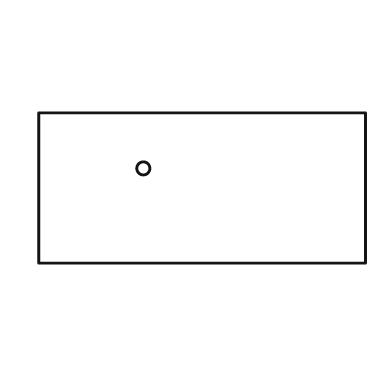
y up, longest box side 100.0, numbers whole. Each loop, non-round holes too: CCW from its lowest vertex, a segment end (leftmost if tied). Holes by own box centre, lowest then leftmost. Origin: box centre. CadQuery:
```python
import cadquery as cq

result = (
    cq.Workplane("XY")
    .moveTo(-50.0, -23.0)
    .lineTo(50.0, -23.0)
    .lineTo(50.0, 23.0)
    .lineTo(-50.0, 23.0)
    .close()
    .moveTo(-18.0, 6.0)
    .circle(2.0)
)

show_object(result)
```